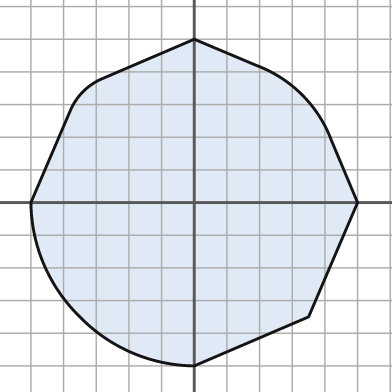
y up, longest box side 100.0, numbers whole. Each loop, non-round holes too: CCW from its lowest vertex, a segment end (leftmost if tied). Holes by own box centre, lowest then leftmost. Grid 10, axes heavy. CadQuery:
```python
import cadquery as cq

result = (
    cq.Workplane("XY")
    .moveTo(0.0, -50.0)
    .lineTo(35.0, -35.0)
    .lineTo(50.0, 0.0)
    .lineTo(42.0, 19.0)
    .threePointArc((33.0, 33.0), (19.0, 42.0))
    .lineTo(0.0, 50.0)
    .lineTo(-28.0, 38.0)
    .threePointArc((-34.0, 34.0), (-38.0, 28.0))
    .lineTo(-50.0, 0.0)
    .threePointArc((-46.0, -19.0), (-35.0, -35.0))
    .threePointArc((-19.0, -46.0), (0.0, -50.0))
    .close()
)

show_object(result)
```